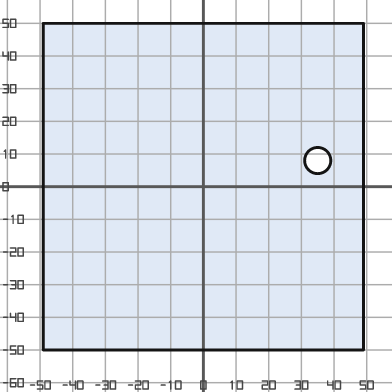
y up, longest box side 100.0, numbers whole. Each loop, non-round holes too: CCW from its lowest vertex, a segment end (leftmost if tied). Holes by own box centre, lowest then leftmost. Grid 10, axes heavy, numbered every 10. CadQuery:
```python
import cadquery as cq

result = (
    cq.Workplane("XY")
    .moveTo(-49.0, -50.0)
    .lineTo(49.0, -50.0)
    .lineTo(49.0, 50.0)
    .lineTo(-49.0, 50.0)
    .close()
    .moveTo(35.0, 8.0)
    .circle(4.0)
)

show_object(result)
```